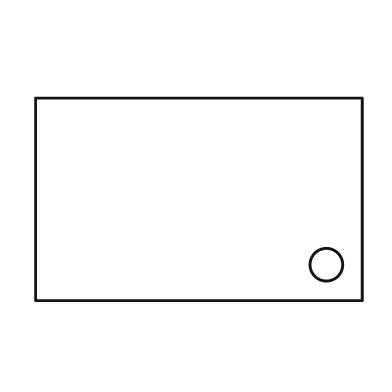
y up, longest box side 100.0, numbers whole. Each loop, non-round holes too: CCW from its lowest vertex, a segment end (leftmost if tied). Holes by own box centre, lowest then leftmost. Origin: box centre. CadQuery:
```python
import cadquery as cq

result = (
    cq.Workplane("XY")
    .moveTo(-50.0, -31.0)
    .lineTo(50.0, -31.0)
    .lineTo(50.0, 31.0)
    .lineTo(-50.0, 31.0)
    .close()
    .moveTo(39.0, -20.0)
    .circle(5.0)
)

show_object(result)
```